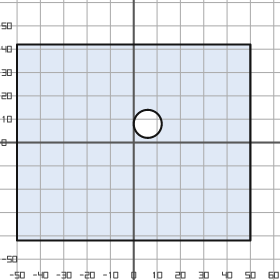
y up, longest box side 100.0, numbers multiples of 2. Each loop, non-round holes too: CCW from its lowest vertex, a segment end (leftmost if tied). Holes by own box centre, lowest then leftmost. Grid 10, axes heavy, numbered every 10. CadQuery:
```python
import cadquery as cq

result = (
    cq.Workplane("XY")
    .moveTo(-50.0, -42.0)
    .lineTo(50.0, -42.0)
    .lineTo(50.0, 42.0)
    .lineTo(-50.0, 42.0)
    .close()
    .moveTo(6.0, 8.0)
    .circle(6.0)
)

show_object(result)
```